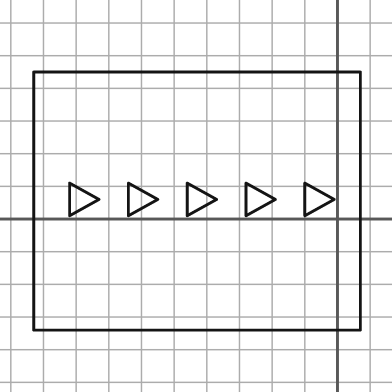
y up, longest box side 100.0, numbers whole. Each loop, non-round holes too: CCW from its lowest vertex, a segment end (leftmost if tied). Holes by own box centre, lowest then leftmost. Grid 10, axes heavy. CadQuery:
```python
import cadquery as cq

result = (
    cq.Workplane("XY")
    .moveTo(-93.0, -34.0)
    .lineTo(7.0, -34.0)
    .lineTo(7.0, 45.0)
    .lineTo(-93.0, 45.0)
    .close()
    .moveTo(-82.0, 1.0)
    .lineTo(-73.0, 6.0)
    .lineTo(-82.0, 11.0)
    .close()
    .moveTo(-64.0, 1.0)
    .lineTo(-55.0, 6.0)
    .lineTo(-64.0, 11.0)
    .close()
    .moveTo(-46.0, 1.0)
    .lineTo(-37.0, 6.0)
    .lineTo(-46.0, 11.0)
    .close()
    .moveTo(-28.0, 1.0)
    .lineTo(-19.0, 6.0)
    .lineTo(-28.0, 11.0)
    .close()
    .moveTo(-10.0, 1.0)
    .lineTo(-1.0, 6.0)
    .lineTo(-10.0, 11.0)
    .close()
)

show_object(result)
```